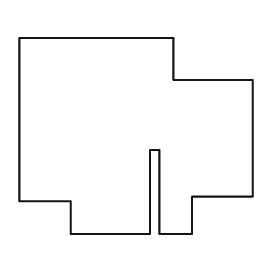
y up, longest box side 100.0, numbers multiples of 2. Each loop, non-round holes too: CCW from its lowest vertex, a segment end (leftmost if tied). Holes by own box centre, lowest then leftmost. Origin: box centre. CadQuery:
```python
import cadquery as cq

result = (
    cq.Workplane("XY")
    .moveTo(-28.0, -42.0)
    .lineTo(6.0, -42.0)
    .lineTo(6.0, -6.0)
    .lineTo(10.0, -6.0)
    .lineTo(10.0, -42.0)
    .lineTo(24.0, -42.0)
    .lineTo(24.0, -26.0)
    .lineTo(50.0, -26.0)
    .lineTo(50.0, 24.0)
    .lineTo(16.0, 24.0)
    .lineTo(16.0, 42.0)
    .lineTo(-50.0, 42.0)
    .lineTo(-50.0, -28.0)
    .lineTo(-28.0, -28.0)
    .close()
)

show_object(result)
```